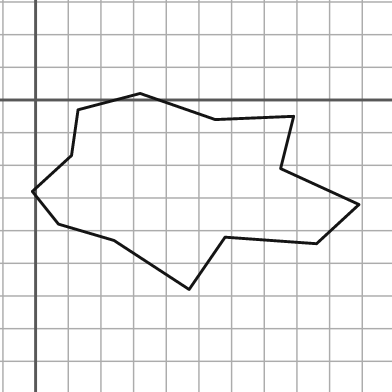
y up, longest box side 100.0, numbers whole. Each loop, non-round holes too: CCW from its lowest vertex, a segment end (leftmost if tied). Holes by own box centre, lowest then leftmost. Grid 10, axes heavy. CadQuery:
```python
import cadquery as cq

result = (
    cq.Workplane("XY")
    .moveTo(47.0, -58.0)
    .lineTo(58.0, -42.0)
    .lineTo(86.0, -44.0)
    .lineTo(99.0, -32.0)
    .lineTo(75.0, -21.0)
    .lineTo(79.0, -5.0)
    .lineTo(55.0, -6.0)
    .lineTo(32.0, 2.0)
    .lineTo(13.0, -3.0)
    .lineTo(11.0, -17.0)
    .lineTo(-1.0, -28.0)
    .lineTo(7.0, -38.0)
    .lineTo(24.0, -43.0)
    .close()
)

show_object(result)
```